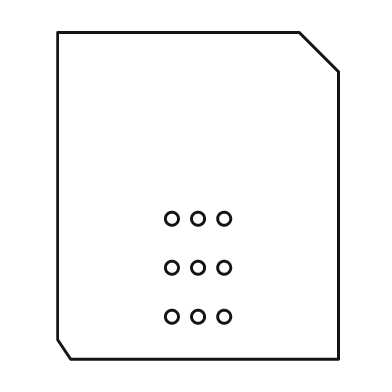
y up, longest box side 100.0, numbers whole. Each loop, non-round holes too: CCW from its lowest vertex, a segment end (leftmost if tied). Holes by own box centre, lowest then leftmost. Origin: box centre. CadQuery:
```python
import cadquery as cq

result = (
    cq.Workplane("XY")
    .moveTo(-39.0, -50.0)
    .lineTo(43.0, -50.0)
    .lineTo(43.0, 38.0)
    .lineTo(31.0, 50.0)
    .lineTo(-43.0, 50.0)
    .lineTo(-43.0, -44.0)
    .close()
    .moveTo(-8.0, -37.0)
    .circle(2.0)
    .moveTo(0.0, -37.0)
    .circle(2.0)
    .moveTo(8.0, -37.0)
    .circle(2.0)
    .moveTo(-8.0, -22.0)
    .circle(2.0)
    .moveTo(0.0, -22.0)
    .circle(2.0)
    .moveTo(8.0, -22.0)
    .circle(2.0)
    .moveTo(-8.0, -7.0)
    .circle(2.0)
    .moveTo(0.0, -7.0)
    .circle(2.0)
    .moveTo(8.0, -7.0)
    .circle(2.0)
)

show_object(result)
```